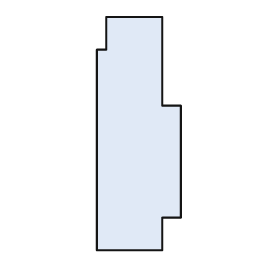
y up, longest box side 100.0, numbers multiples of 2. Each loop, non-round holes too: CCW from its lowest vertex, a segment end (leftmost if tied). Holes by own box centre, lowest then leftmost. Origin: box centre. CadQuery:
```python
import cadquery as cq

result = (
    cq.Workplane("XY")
    .moveTo(-18.0, -50.0)
    .lineTo(10.0, -50.0)
    .lineTo(10.0, -36.0)
    .lineTo(18.0, -36.0)
    .lineTo(18.0, 12.0)
    .lineTo(10.0, 12.0)
    .lineTo(10.0, 50.0)
    .lineTo(-14.0, 50.0)
    .lineTo(-14.0, 36.0)
    .lineTo(-18.0, 36.0)
    .close()
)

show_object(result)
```